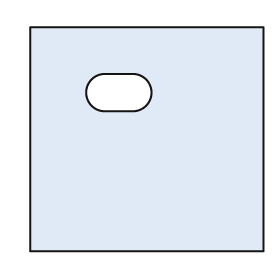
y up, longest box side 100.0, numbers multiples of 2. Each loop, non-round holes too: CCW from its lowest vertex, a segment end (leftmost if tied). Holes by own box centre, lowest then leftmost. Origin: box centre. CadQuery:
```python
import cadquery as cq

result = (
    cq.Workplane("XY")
    .moveTo(-50.0, -48.0)
    .lineTo(50.0, -48.0)
    .lineTo(50.0, 48.0)
    .lineTo(-50.0, 48.0)
    .close()
    .moveTo(-18.0, 12.0)
    .lineTo(-6.0, 12.0)
    .threePointArc((2.0, 20.0), (-6.0, 28.0))
    .lineTo(-18.0, 28.0)
    .threePointArc((-26.0, 20.0), (-18.0, 12.0))
    .close()
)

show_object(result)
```